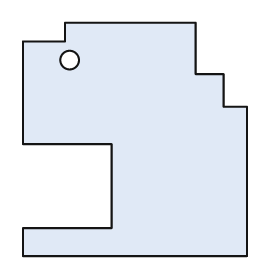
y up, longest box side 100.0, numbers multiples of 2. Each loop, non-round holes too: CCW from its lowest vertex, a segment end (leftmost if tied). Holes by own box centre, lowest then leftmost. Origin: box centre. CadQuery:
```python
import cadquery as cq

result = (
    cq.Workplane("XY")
    .moveTo(-48.0, -50.0)
    .lineTo(48.0, -50.0)
    .lineTo(48.0, 14.0)
    .lineTo(38.0, 14.0)
    .lineTo(38.0, 28.0)
    .lineTo(26.0, 28.0)
    .lineTo(26.0, 50.0)
    .lineTo(-30.0, 50.0)
    .lineTo(-30.0, 42.0)
    .lineTo(-48.0, 42.0)
    .lineTo(-48.0, -2.0)
    .lineTo(-10.0, -2.0)
    .lineTo(-10.0, -38.0)
    .lineTo(-48.0, -38.0)
    .close()
    .moveTo(-28.0, 34.0)
    .circle(4.0)
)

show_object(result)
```